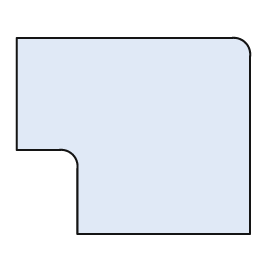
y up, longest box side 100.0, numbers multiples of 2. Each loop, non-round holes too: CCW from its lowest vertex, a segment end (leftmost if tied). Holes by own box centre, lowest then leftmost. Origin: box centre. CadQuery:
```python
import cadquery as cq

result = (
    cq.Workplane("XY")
    .moveTo(-24.0, -42.0)
    .lineTo(50.0, -42.0)
    .lineTo(50.0, 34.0)
    .threePointArc((48.0, 40.0), (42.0, 42.0))
    .lineTo(-50.0, 42.0)
    .lineTo(-50.0, -6.0)
    .lineTo(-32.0, -6.0)
    .threePointArc((-26.0, -8.0), (-24.0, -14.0))
    .close()
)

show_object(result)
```